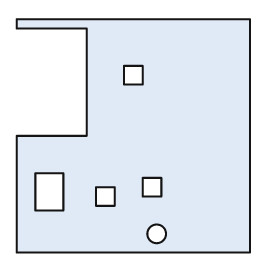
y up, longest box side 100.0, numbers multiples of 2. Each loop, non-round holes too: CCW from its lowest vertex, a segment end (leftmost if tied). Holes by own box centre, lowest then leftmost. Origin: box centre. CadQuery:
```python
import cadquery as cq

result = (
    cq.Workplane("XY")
    .moveTo(-50.0, -50.0)
    .lineTo(50.0, -50.0)
    .lineTo(50.0, 50.0)
    .lineTo(-50.0, 50.0)
    .lineTo(-50.0, 46.0)
    .lineTo(-20.0, 46.0)
    .lineTo(-20.0, 0.0)
    .lineTo(-50.0, 0.0)
    .close()
    .moveTo(10.0, -42.0)
    .circle(4.0)
    .moveTo(-16.0, -30.0)
    .lineTo(-8.0, -30.0)
    .lineTo(-8.0, -22.0)
    .lineTo(-16.0, -22.0)
    .close()
    .moveTo(-42.0, -32.0)
    .lineTo(-30.0, -32.0)
    .lineTo(-30.0, -16.0)
    .lineTo(-42.0, -16.0)
    .close()
    .moveTo(4.0, -26.0)
    .lineTo(12.0, -26.0)
    .lineTo(12.0, -18.0)
    .lineTo(4.0, -18.0)
    .close()
    .moveTo(-4.0, 22.0)
    .lineTo(4.0, 22.0)
    .lineTo(4.0, 30.0)
    .lineTo(-4.0, 30.0)
    .close()
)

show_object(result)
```